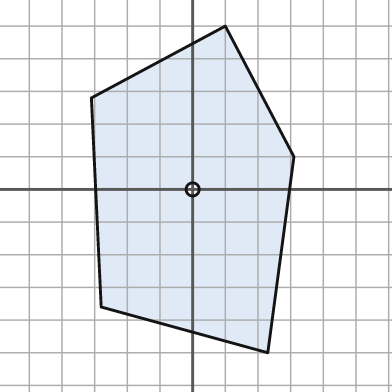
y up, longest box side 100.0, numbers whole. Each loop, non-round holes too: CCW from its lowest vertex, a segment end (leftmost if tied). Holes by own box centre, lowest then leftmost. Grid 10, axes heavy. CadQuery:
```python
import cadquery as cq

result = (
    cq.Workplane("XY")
    .moveTo(23.0, -50.0)
    .lineTo(31.0, 10.0)
    .lineTo(10.0, 50.0)
    .lineTo(-31.0, 28.0)
    .lineTo(-28.0, -36.0)
    .close()
    .moveTo(0.0, 0.0)
    .circle(2.0)
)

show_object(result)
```